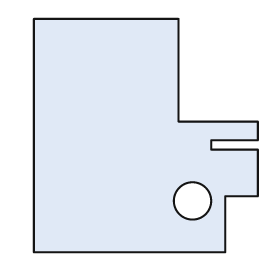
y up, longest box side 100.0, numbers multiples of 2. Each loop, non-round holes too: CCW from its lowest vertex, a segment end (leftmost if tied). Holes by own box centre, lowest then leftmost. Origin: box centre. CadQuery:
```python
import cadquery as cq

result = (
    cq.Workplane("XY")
    .moveTo(-48.0, -50.0)
    .lineTo(34.0, -50.0)
    .lineTo(34.0, -26.0)
    .lineTo(48.0, -26.0)
    .lineTo(48.0, -6.0)
    .lineTo(28.0, -6.0)
    .lineTo(28.0, -2.0)
    .lineTo(48.0, -2.0)
    .lineTo(48.0, 6.0)
    .lineTo(14.0, 6.0)
    .lineTo(14.0, 50.0)
    .lineTo(-48.0, 50.0)
    .close()
    .moveTo(20.0, -28.0)
    .circle(8.0)
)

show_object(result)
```